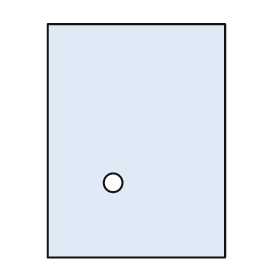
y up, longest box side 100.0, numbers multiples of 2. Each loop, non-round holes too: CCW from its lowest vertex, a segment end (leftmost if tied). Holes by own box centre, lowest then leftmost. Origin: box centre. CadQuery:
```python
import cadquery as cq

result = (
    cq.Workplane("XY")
    .moveTo(-38.0, -50.0)
    .lineTo(38.0, -50.0)
    .lineTo(38.0, 50.0)
    .lineTo(-38.0, 50.0)
    .close()
    .moveTo(-10.0, -18.0)
    .circle(4.0)
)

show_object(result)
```